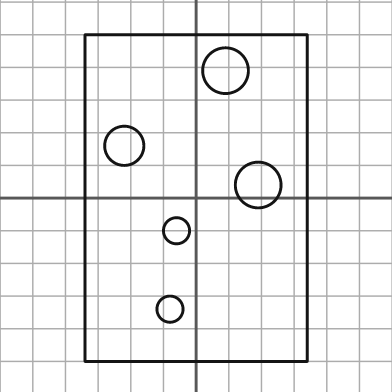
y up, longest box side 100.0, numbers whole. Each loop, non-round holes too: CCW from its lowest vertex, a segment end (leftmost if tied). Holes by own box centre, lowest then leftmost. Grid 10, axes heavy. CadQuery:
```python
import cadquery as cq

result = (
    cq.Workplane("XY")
    .moveTo(-34.0, -50.0)
    .lineTo(34.0, -50.0)
    .lineTo(34.0, 50.0)
    .lineTo(-34.0, 50.0)
    .close()
    .moveTo(-8.0, -34.0)
    .circle(4.0)
    .moveTo(-6.0, -10.0)
    .circle(4.0)
    .moveTo(19.0, 4.0)
    .circle(7.0)
    .moveTo(-22.0, 16.0)
    .circle(6.0)
    .moveTo(9.0, 39.0)
    .circle(7.0)
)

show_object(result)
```